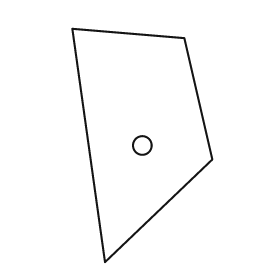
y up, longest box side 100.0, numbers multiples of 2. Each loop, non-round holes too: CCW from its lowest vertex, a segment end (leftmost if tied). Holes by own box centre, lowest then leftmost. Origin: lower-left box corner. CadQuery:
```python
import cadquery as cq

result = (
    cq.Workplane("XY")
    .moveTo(14.0, 0.0)
    .lineTo(60.0, 44.0)
    .lineTo(48.0, 96.0)
    .lineTo(0.0, 100.0)
    .close()
    .moveTo(30.0, 50.0)
    .circle(4.0)
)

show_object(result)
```